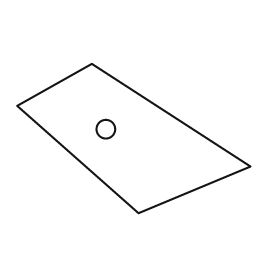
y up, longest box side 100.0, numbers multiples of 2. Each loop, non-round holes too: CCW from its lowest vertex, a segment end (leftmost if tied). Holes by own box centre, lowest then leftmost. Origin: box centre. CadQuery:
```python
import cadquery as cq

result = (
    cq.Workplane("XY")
    .moveTo(2.0, -32.0)
    .lineTo(50.0, -12.0)
    .lineTo(-18.0, 32.0)
    .lineTo(-50.0, 14.0)
    .close()
    .moveTo(-12.0, 4.0)
    .circle(4.0)
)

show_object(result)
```